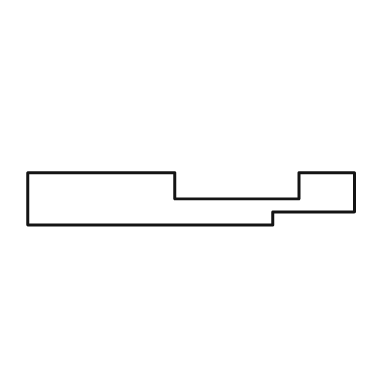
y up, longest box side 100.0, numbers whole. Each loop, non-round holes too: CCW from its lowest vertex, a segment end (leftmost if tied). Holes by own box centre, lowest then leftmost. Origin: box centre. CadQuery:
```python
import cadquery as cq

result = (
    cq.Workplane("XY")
    .moveTo(-50.0, -8.0)
    .lineTo(25.0, -8.0)
    .lineTo(25.0, -4.0)
    .lineTo(50.0, -4.0)
    .lineTo(50.0, 8.0)
    .lineTo(33.0, 8.0)
    .lineTo(33.0, 0.0)
    .lineTo(-5.0, 0.0)
    .lineTo(-5.0, 8.0)
    .lineTo(-50.0, 8.0)
    .close()
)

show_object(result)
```